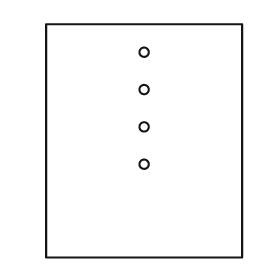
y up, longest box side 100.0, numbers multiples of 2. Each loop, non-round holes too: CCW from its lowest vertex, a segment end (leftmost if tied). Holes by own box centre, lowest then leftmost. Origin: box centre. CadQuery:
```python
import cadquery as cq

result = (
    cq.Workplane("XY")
    .moveTo(-42.0, -50.0)
    .lineTo(42.0, -50.0)
    .lineTo(42.0, 50.0)
    .lineTo(-42.0, 50.0)
    .close()
    .moveTo(0.0, -10.0)
    .circle(2.0)
    .moveTo(0.0, 6.0)
    .circle(2.0)
    .moveTo(0.0, 22.0)
    .circle(2.0)
    .moveTo(0.0, 38.0)
    .circle(2.0)
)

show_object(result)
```